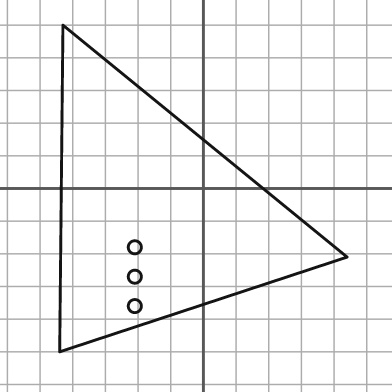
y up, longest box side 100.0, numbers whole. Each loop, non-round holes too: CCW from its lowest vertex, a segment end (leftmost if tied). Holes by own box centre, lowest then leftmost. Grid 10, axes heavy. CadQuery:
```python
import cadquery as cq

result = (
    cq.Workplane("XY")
    .moveTo(-44.0, -50.0)
    .lineTo(44.0, -21.0)
    .lineTo(-43.0, 50.0)
    .close()
    .moveTo(-21.0, -36.0)
    .circle(2.0)
    .moveTo(-21.0, -27.0)
    .circle(2.0)
    .moveTo(-21.0, -18.0)
    .circle(2.0)
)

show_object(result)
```